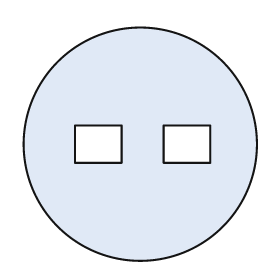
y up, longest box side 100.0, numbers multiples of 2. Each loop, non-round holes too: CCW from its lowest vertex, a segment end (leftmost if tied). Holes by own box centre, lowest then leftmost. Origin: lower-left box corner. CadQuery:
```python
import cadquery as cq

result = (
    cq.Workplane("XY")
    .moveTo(50.0, 50.0)
    .circle(50.0)
    .moveTo(22.0, 42.0)
    .lineTo(42.0, 42.0)
    .lineTo(42.0, 58.0)
    .lineTo(22.0, 58.0)
    .close()
    .moveTo(60.0, 42.0)
    .lineTo(80.0, 42.0)
    .lineTo(80.0, 58.0)
    .lineTo(60.0, 58.0)
    .close()
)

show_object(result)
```